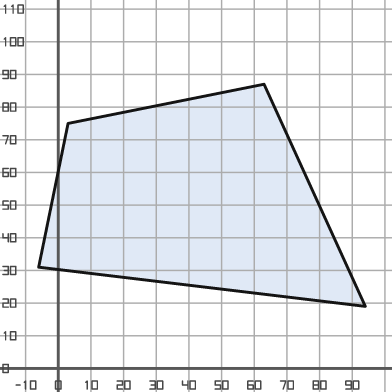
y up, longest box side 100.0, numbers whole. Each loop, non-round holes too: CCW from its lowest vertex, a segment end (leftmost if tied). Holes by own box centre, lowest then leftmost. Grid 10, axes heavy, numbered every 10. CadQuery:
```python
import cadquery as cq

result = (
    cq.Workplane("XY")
    .moveTo(94.0, 19.0)
    .lineTo(63.0, 87.0)
    .lineTo(3.0, 75.0)
    .lineTo(-6.0, 31.0)
    .close()
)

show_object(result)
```